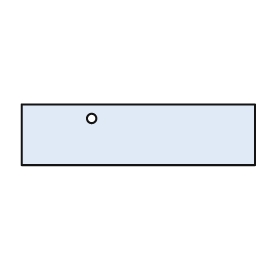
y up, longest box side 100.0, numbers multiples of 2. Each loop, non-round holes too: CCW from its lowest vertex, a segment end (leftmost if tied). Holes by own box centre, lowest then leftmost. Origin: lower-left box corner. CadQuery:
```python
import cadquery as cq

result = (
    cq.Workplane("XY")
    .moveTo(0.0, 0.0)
    .lineTo(100.0, 0.0)
    .lineTo(100.0, 26.0)
    .lineTo(0.0, 26.0)
    .close()
    .moveTo(30.0, 20.0)
    .circle(2.0)
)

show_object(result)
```